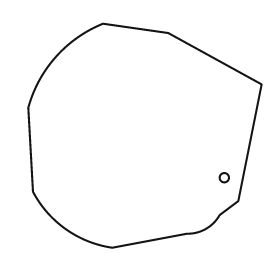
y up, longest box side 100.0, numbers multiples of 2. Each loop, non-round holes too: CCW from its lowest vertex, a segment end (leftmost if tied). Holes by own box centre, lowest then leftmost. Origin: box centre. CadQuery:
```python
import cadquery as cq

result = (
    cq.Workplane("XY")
    .moveTo(-14.0, -48.0)
    .lineTo(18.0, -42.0)
    .threePointArc((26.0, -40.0), (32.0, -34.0))
    .lineTo(40.0, -28.0)
    .lineTo(50.0, 22.0)
    .lineTo(10.0, 44.0)
    .lineTo(-18.0, 48.0)
    .threePointArc((-38.0, 34.0), (-50.0, 12.0))
    .lineTo(-48.0, -24.0)
    .threePointArc((-34.0, -40.0), (-14.0, -48.0))
    .close()
    .moveTo(34.0, -18.0)
    .circle(2.0)
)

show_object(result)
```